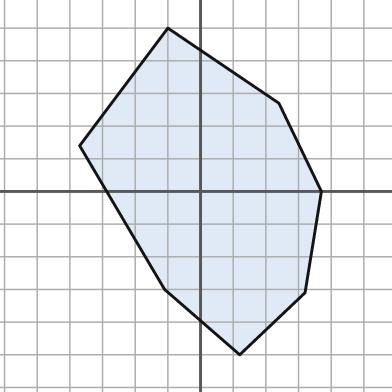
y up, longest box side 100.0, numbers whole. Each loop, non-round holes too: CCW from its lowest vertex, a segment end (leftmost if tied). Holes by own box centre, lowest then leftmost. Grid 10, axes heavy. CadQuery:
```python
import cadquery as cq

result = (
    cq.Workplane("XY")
    .moveTo(12.0, -50.0)
    .lineTo(32.0, -31.0)
    .lineTo(37.0, 0.0)
    .lineTo(24.0, 27.0)
    .lineTo(-10.0, 50.0)
    .lineTo(-37.0, 14.0)
    .lineTo(-11.0, -30.0)
    .close()
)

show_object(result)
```